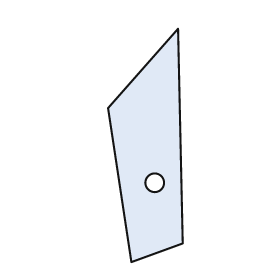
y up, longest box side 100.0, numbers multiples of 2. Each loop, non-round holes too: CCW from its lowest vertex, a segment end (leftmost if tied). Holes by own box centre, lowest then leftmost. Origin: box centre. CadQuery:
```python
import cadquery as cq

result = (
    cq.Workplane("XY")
    .moveTo(-6.0, -50.0)
    .lineTo(16.0, -42.0)
    .lineTo(14.0, 50.0)
    .lineTo(-16.0, 16.0)
    .close()
    .moveTo(4.0, -16.0)
    .circle(4.0)
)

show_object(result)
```